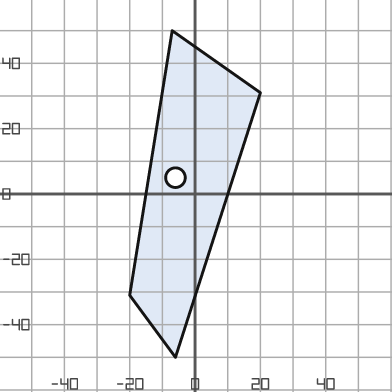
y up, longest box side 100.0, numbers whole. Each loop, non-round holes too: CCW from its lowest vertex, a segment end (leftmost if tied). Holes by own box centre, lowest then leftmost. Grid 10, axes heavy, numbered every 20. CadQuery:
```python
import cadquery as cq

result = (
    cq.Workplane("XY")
    .moveTo(-6.0, -50.0)
    .lineTo(20.0, 31.0)
    .lineTo(-7.0, 50.0)
    .lineTo(-20.0, -31.0)
    .close()
    .moveTo(-6.0, 5.0)
    .circle(3.0)
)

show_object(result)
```